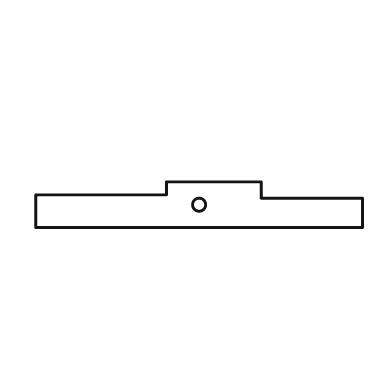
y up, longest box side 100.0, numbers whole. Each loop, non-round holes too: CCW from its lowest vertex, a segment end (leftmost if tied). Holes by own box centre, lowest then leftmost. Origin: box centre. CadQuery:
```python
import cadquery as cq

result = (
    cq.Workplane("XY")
    .moveTo(-50.0, -7.0)
    .lineTo(50.0, -7.0)
    .lineTo(50.0, 2.0)
    .lineTo(19.0, 2.0)
    .lineTo(19.0, 7.0)
    .lineTo(-10.0, 7.0)
    .lineTo(-10.0, 3.0)
    .lineTo(-50.0, 3.0)
    .close()
    .moveTo(0.0, 0.0)
    .circle(2.0)
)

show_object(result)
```